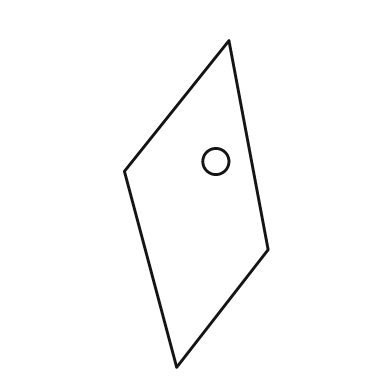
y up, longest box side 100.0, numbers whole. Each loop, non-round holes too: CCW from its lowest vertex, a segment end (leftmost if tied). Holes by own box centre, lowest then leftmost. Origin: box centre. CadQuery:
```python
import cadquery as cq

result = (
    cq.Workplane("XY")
    .moveTo(-6.0, -50.0)
    .lineTo(22.0, -14.0)
    .lineTo(10.0, 50.0)
    .lineTo(-22.0, 10.0)
    .close()
    .moveTo(6.0, 13.0)
    .circle(4.0)
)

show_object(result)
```